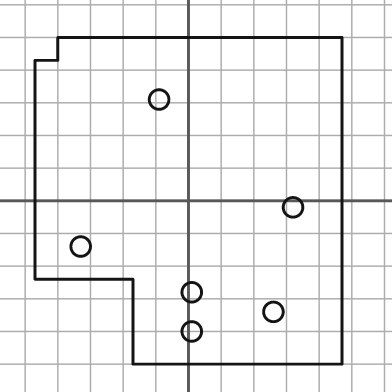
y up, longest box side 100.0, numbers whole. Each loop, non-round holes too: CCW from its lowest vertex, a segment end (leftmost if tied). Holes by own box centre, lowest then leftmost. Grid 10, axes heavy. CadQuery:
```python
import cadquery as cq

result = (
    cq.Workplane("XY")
    .moveTo(-17.0, -50.0)
    .lineTo(47.0, -50.0)
    .lineTo(47.0, 50.0)
    .lineTo(-40.0, 50.0)
    .lineTo(-40.0, 43.0)
    .lineTo(-47.0, 43.0)
    .lineTo(-47.0, -24.0)
    .lineTo(-17.0, -24.0)
    .close()
    .moveTo(1.0, -40.0)
    .circle(3.0)
    .moveTo(26.0, -34.0)
    .circle(3.0)
    .moveTo(1.0, -28.0)
    .circle(3.0)
    .moveTo(-33.0, -14.0)
    .circle(3.0)
    .moveTo(32.0, -2.0)
    .circle(3.0)
    .moveTo(-9.0, 31.0)
    .circle(3.0)
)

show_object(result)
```